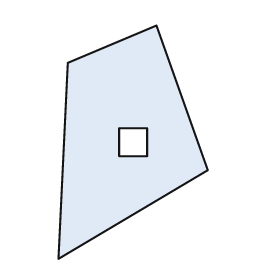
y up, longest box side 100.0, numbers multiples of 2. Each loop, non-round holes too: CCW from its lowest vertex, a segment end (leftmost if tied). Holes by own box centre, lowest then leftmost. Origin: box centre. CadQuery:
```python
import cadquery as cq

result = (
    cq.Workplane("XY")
    .moveTo(-32.0, -50.0)
    .lineTo(32.0, -12.0)
    .lineTo(10.0, 50.0)
    .lineTo(-28.0, 34.0)
    .close()
    .moveTo(-6.0, -6.0)
    .lineTo(6.0, -6.0)
    .lineTo(6.0, 6.0)
    .lineTo(-6.0, 6.0)
    .close()
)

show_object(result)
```